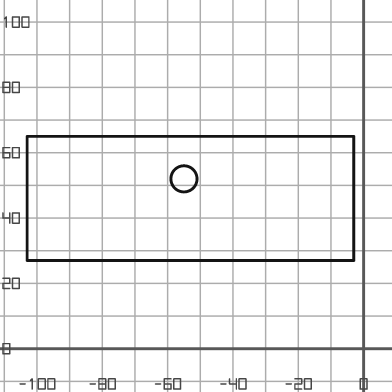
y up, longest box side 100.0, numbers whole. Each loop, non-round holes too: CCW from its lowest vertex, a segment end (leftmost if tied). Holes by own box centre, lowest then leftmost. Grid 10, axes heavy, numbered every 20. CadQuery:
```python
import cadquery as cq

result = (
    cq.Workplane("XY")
    .moveTo(-103.0, 27.0)
    .lineTo(-3.0, 27.0)
    .lineTo(-3.0, 65.0)
    .lineTo(-103.0, 65.0)
    .close()
    .moveTo(-55.0, 52.0)
    .circle(4.0)
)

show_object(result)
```